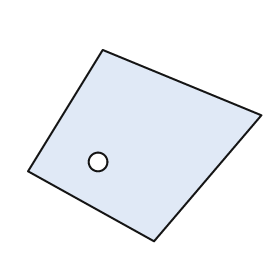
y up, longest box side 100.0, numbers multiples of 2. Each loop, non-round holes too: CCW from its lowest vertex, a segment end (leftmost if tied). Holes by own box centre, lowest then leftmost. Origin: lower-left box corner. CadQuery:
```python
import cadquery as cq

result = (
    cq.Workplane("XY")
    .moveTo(54.0, 0.0)
    .lineTo(100.0, 54.0)
    .lineTo(32.0, 82.0)
    .lineTo(0.0, 30.0)
    .close()
    .moveTo(30.0, 34.0)
    .circle(4.0)
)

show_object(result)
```